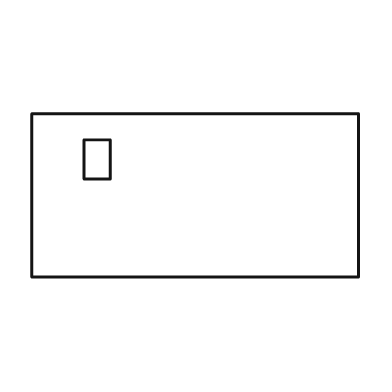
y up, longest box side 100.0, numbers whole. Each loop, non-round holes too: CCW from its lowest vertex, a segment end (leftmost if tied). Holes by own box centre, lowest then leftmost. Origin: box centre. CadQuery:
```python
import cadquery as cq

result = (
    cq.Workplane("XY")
    .moveTo(-50.0, -25.0)
    .lineTo(50.0, -25.0)
    .lineTo(50.0, 25.0)
    .lineTo(-50.0, 25.0)
    .close()
    .moveTo(-34.0, 5.0)
    .lineTo(-26.0, 5.0)
    .lineTo(-26.0, 17.0)
    .lineTo(-34.0, 17.0)
    .close()
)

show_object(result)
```